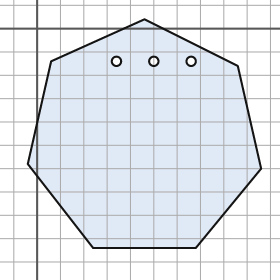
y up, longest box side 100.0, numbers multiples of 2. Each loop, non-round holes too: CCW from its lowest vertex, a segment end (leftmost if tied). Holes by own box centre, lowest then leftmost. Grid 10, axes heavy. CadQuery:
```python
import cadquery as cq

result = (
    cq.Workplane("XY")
    .moveTo(24.0, -94.0)
    .lineTo(68.0, -94.0)
    .lineTo(96.0, -60.0)
    .lineTo(86.0, -16.0)
    .lineTo(46.0, 4.0)
    .lineTo(6.0, -14.0)
    .lineTo(-4.0, -58.0)
    .close()
    .moveTo(34.0, -14.0)
    .circle(2.0)
    .moveTo(50.0, -14.0)
    .circle(2.0)
    .moveTo(66.0, -14.0)
    .circle(2.0)
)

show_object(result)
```